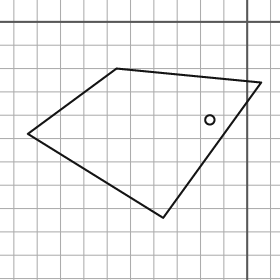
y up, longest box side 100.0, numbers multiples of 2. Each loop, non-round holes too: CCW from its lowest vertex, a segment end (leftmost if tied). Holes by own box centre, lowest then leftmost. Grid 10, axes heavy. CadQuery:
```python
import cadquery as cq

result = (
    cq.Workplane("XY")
    .moveTo(-36.0, -84.0)
    .lineTo(6.0, -26.0)
    .lineTo(-56.0, -20.0)
    .lineTo(-94.0, -48.0)
    .close()
    .moveTo(-16.0, -42.0)
    .circle(2.0)
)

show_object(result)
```